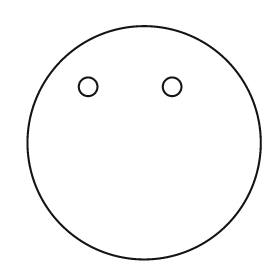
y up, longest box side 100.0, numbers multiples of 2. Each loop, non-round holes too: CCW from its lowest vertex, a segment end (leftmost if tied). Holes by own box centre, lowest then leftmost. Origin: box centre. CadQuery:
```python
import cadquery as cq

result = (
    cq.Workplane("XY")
    .moveTo(0.0, 0.0)
    .circle(50.0)
    .moveTo(-24.0, 24.0)
    .circle(4.0)
    .moveTo(12.0, 24.0)
    .circle(4.0)
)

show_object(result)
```